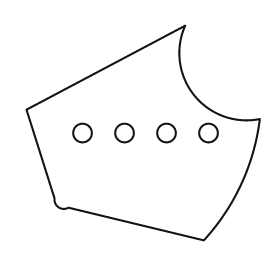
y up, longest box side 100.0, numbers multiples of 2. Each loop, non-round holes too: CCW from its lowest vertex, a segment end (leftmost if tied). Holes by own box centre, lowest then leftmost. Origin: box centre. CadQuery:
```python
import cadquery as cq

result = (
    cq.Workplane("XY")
    .moveTo(26.0, -46.0)
    .threePointArc((42.0, -22.0), (50.0, 6.0))
    .threePointArc((22.0, 16.0), (18.0, 46.0))
    .lineTo(-50.0, 10.0)
    .lineTo(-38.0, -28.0)
    .threePointArc((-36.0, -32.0), (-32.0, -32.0))
    .close()
    .moveTo(-26.0, 0.0)
    .circle(4.0)
    .moveTo(-8.0, 0.0)
    .circle(4.0)
    .moveTo(10.0, 0.0)
    .circle(4.0)
    .moveTo(28.0, 0.0)
    .circle(4.0)
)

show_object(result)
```